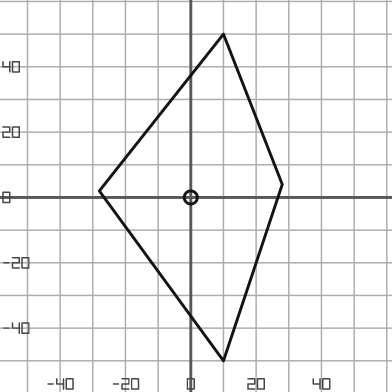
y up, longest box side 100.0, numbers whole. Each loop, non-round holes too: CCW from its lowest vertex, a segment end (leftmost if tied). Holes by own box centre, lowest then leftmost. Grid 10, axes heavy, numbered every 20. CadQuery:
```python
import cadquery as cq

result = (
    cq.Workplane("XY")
    .moveTo(10.0, -50.0)
    .lineTo(28.0, 4.0)
    .lineTo(10.0, 50.0)
    .lineTo(-28.0, 2.0)
    .close()
    .moveTo(0.0, 0.0)
    .circle(2.0)
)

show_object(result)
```